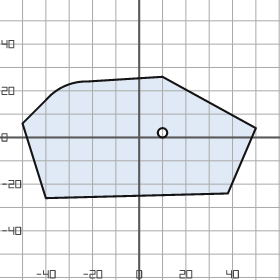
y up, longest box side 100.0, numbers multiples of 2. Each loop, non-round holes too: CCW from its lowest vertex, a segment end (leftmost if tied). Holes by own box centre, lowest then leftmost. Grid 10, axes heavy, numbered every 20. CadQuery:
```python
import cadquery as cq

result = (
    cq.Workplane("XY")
    .moveTo(-40.0, -26.0)
    .lineTo(38.0, -24.0)
    .lineTo(50.0, 4.0)
    .lineTo(10.0, 26.0)
    .lineTo(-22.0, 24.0)
    .threePointArc((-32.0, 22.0), (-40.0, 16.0))
    .lineTo(-50.0, 6.0)
    .close()
    .moveTo(10.0, 2.0)
    .circle(2.0)
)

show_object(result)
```